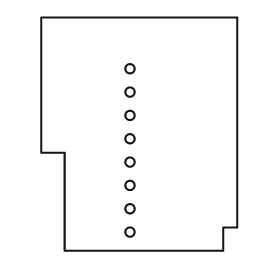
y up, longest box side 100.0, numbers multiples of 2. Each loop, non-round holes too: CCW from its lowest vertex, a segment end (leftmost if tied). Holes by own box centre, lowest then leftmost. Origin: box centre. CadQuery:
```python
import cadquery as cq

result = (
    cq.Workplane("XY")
    .moveTo(-32.0, -50.0)
    .lineTo(36.0, -50.0)
    .lineTo(36.0, -40.0)
    .lineTo(42.0, -40.0)
    .lineTo(42.0, 50.0)
    .lineTo(-42.0, 50.0)
    .lineTo(-42.0, -8.0)
    .lineTo(-32.0, -8.0)
    .close()
    .moveTo(-4.0, -42.0)
    .circle(2.0)
    .moveTo(-4.0, -32.0)
    .circle(2.0)
    .moveTo(-4.0, -22.0)
    .circle(2.0)
    .moveTo(-4.0, -12.0)
    .circle(2.0)
    .moveTo(-4.0, -2.0)
    .circle(2.0)
    .moveTo(-4.0, 8.0)
    .circle(2.0)
    .moveTo(-4.0, 18.0)
    .circle(2.0)
    .moveTo(-4.0, 28.0)
    .circle(2.0)
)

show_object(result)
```